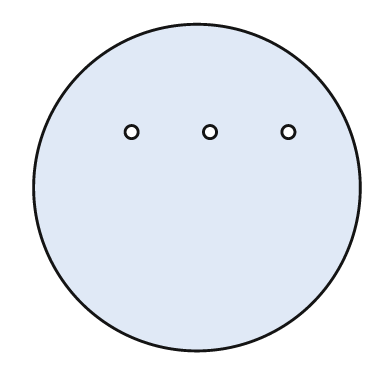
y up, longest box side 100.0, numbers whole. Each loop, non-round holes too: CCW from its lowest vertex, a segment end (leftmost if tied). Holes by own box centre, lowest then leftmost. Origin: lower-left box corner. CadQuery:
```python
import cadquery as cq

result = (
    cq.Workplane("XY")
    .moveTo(50.0, 50.0)
    .circle(50.0)
    .moveTo(30.0, 67.0)
    .circle(2.0)
    .moveTo(54.0, 67.0)
    .circle(2.0)
    .moveTo(78.0, 67.0)
    .circle(2.0)
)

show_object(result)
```